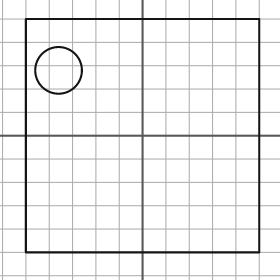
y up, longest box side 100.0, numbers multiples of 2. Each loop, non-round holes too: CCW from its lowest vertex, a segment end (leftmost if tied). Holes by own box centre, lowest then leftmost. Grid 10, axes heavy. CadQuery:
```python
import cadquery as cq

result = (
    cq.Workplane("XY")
    .moveTo(-50.0, -50.0)
    .lineTo(50.0, -50.0)
    .lineTo(50.0, 50.0)
    .lineTo(-50.0, 50.0)
    .close()
    .moveTo(-36.0, 28.0)
    .circle(10.0)
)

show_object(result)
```